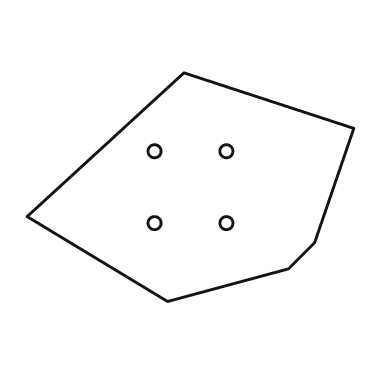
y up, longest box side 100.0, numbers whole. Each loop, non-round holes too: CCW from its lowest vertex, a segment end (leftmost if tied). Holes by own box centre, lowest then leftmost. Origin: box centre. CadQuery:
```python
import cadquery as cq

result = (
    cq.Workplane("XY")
    .moveTo(-7.0, -35.0)
    .lineTo(30.0, -25.0)
    .lineTo(38.0, -17.0)
    .lineTo(50.0, 18.0)
    .lineTo(-2.0, 35.0)
    .lineTo(-50.0, -9.0)
    .close()
    .moveTo(-11.0, -11.0)
    .circle(2.0)
    .moveTo(11.0, -11.0)
    .circle(2.0)
    .moveTo(-11.0, 11.0)
    .circle(2.0)
    .moveTo(11.0, 11.0)
    .circle(2.0)
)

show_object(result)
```